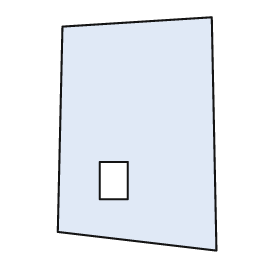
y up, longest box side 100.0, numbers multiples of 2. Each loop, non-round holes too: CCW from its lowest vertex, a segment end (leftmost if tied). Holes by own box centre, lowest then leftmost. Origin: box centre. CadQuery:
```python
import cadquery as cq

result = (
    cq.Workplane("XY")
    .moveTo(34.0, -50.0)
    .lineTo(32.0, 50.0)
    .lineTo(-32.0, 46.0)
    .lineTo(-34.0, -42.0)
    .close()
    .moveTo(-16.0, -28.0)
    .lineTo(-4.0, -28.0)
    .lineTo(-4.0, -12.0)
    .lineTo(-16.0, -12.0)
    .close()
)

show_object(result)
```